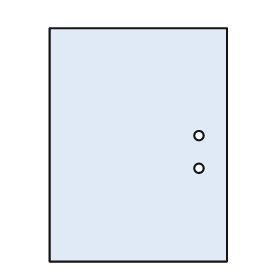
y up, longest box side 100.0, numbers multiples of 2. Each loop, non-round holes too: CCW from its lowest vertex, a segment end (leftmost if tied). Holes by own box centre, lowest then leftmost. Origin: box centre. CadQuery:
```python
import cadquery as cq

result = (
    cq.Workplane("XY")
    .moveTo(-38.0, -50.0)
    .lineTo(38.0, -50.0)
    .lineTo(38.0, 50.0)
    .lineTo(-38.0, 50.0)
    .close()
    .moveTo(26.0, -10.0)
    .circle(2.0)
    .moveTo(26.0, 4.0)
    .circle(2.0)
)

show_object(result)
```